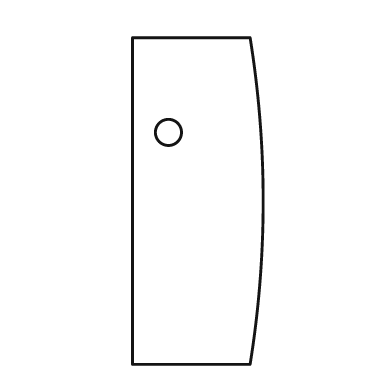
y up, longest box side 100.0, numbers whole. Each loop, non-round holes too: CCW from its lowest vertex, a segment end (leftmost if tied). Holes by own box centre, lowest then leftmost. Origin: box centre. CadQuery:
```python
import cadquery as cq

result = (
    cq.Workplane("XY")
    .moveTo(-20.0, -50.0)
    .lineTo(16.0, -50.0)
    .threePointArc((20.0, 0.0), (16.0, 50.0))
    .lineTo(-20.0, 50.0)
    .close()
    .moveTo(-9.0, 21.0)
    .circle(4.0)
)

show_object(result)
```